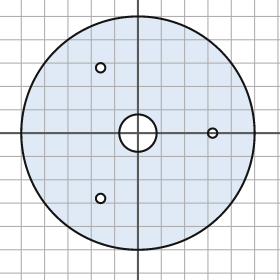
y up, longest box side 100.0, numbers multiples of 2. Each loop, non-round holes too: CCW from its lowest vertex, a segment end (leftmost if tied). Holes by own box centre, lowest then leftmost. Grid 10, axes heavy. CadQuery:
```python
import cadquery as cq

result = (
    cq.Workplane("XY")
    .moveTo(0.0, 0.0)
    .circle(50.0)
    .moveTo(-16.0, -28.0)
    .circle(2.0)
    .moveTo(0.0, 0.0)
    .circle(8.0)
    .moveTo(32.0, 0.0)
    .circle(2.0)
    .moveTo(-16.0, 28.0)
    .circle(2.0)
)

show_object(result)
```